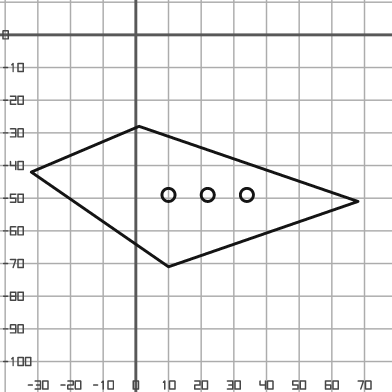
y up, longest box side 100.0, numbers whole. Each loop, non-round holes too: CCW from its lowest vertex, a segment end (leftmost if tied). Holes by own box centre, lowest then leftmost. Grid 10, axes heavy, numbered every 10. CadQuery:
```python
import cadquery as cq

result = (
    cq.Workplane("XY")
    .moveTo(10.0, -71.0)
    .lineTo(68.0, -51.0)
    .lineTo(1.0, -28.0)
    .lineTo(-32.0, -42.0)
    .close()
    .moveTo(10.0, -49.0)
    .circle(2.0)
    .moveTo(22.0, -49.0)
    .circle(2.0)
    .moveTo(34.0, -49.0)
    .circle(2.0)
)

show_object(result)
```